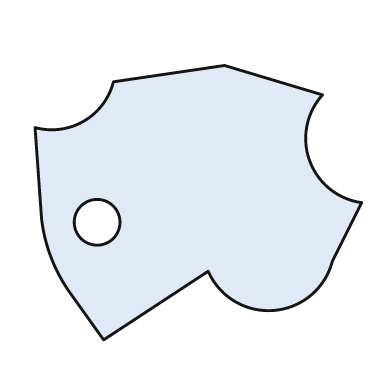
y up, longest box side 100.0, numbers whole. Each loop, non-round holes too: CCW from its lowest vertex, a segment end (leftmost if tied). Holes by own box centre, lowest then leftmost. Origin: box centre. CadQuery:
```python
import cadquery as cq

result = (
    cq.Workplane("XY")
    .moveTo(-29.0, -42.0)
    .lineTo(3.0, -21.0)
    .threePointArc((23.0, -33.0), (41.0, -18.0))
    .lineTo(50.0, 0.0)
    .threePointArc((34.0, 13.0), (38.0, 33.0))
    .lineTo(8.0, 42.0)
    .lineTo(-26.0, 37.0)
    .threePointArc((-35.0, 25.0), (-50.0, 23.0))
    .lineTo(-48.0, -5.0)
    .threePointArc((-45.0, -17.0), (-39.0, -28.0))
    .close()
    .moveTo(-31.0, -6.0)
    .circle(7.0)
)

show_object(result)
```